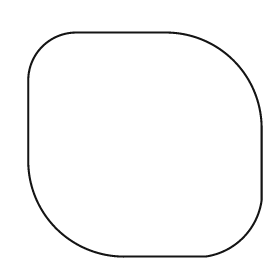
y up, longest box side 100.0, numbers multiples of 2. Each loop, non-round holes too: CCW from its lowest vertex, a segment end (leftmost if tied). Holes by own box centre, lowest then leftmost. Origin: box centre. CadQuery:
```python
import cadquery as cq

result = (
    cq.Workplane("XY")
    .moveTo(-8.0, -48.0)
    .lineTo(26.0, -48.0)
    .threePointArc((42.0, -40.0), (50.0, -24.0))
    .lineTo(50.0, 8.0)
    .threePointArc((38.0, 36.0), (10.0, 48.0))
    .lineTo(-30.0, 48.0)
    .threePointArc((-44.0, 42.0), (-50.0, 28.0))
    .lineTo(-50.0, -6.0)
    .threePointArc((-38.0, -36.0), (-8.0, -48.0))
    .close()
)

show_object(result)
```